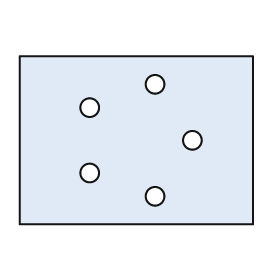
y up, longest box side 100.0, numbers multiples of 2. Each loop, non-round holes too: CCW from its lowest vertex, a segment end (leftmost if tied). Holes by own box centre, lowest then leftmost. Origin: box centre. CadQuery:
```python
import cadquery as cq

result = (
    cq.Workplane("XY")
    .moveTo(-50.0, -36.0)
    .lineTo(50.0, -36.0)
    .lineTo(50.0, 36.0)
    .lineTo(-50.0, 36.0)
    .close()
    .moveTo(8.0, -24.0)
    .circle(4.0)
    .moveTo(-20.0, -14.0)
    .circle(4.0)
    .moveTo(24.0, 0.0)
    .circle(4.0)
    .moveTo(-20.0, 14.0)
    .circle(4.0)
    .moveTo(8.0, 24.0)
    .circle(4.0)
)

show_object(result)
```